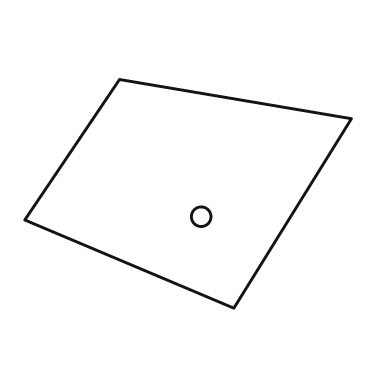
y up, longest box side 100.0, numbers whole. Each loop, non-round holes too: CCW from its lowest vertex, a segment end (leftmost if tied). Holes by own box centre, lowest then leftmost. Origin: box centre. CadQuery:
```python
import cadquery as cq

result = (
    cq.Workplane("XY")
    .moveTo(14.0, -35.0)
    .lineTo(50.0, 23.0)
    .lineTo(-21.0, 35.0)
    .lineTo(-50.0, -8.0)
    .close()
    .moveTo(4.0, -7.0)
    .circle(3.0)
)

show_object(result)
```